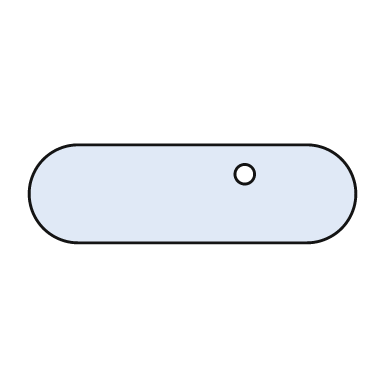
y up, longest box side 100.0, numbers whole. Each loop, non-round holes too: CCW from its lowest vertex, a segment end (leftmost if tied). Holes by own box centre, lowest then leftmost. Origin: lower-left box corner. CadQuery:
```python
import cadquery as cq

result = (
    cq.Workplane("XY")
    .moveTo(15.0, 0.0)
    .lineTo(85.0, 0.0)
    .threePointArc((100.0, 15.0), (85.0, 30.0))
    .lineTo(15.0, 30.0)
    .threePointArc((0.0, 15.0), (15.0, 0.0))
    .close()
    .moveTo(66.0, 21.0)
    .circle(3.0)
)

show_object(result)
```